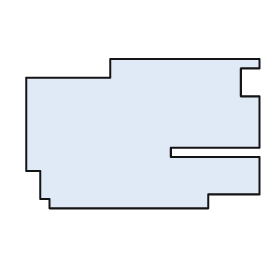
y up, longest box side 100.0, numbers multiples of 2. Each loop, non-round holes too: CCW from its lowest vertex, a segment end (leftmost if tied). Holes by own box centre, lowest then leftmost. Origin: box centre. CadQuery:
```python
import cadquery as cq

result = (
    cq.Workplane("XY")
    .moveTo(-40.0, -32.0)
    .lineTo(28.0, -32.0)
    .lineTo(28.0, -26.0)
    .lineTo(50.0, -26.0)
    .lineTo(50.0, -10.0)
    .lineTo(12.0, -10.0)
    .lineTo(12.0, -6.0)
    .lineTo(50.0, -6.0)
    .lineTo(50.0, 16.0)
    .lineTo(42.0, 16.0)
    .lineTo(42.0, 28.0)
    .lineTo(50.0, 28.0)
    .lineTo(50.0, 32.0)
    .lineTo(-14.0, 32.0)
    .lineTo(-14.0, 24.0)
    .lineTo(-50.0, 24.0)
    .lineTo(-50.0, -16.0)
    .lineTo(-44.0, -16.0)
    .lineTo(-44.0, -28.0)
    .lineTo(-40.0, -28.0)
    .close()
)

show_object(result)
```